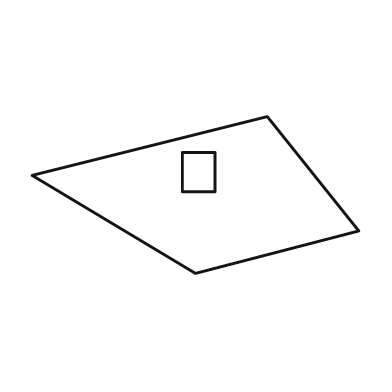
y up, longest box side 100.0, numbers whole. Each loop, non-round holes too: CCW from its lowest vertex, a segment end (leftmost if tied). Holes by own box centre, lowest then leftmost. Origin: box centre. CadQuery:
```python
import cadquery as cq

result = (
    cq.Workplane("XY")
    .moveTo(0.0, -24.0)
    .lineTo(50.0, -11.0)
    .lineTo(22.0, 24.0)
    .lineTo(-50.0, 6.0)
    .close()
    .moveTo(-4.0, 1.0)
    .lineTo(6.0, 1.0)
    .lineTo(6.0, 13.0)
    .lineTo(-4.0, 13.0)
    .close()
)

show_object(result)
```